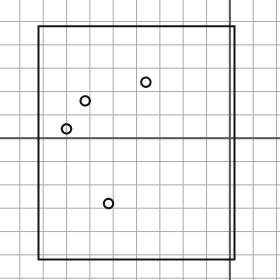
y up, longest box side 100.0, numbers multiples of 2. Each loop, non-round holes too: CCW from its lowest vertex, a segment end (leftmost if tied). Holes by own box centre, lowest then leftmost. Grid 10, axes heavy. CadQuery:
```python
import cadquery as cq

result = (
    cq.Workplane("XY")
    .moveTo(-82.0, -52.0)
    .lineTo(2.0, -52.0)
    .lineTo(2.0, 48.0)
    .lineTo(-82.0, 48.0)
    .close()
    .moveTo(-52.0, -28.0)
    .circle(2.0)
    .moveTo(-70.0, 4.0)
    .circle(2.0)
    .moveTo(-62.0, 16.0)
    .circle(2.0)
    .moveTo(-36.0, 24.0)
    .circle(2.0)
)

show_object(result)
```